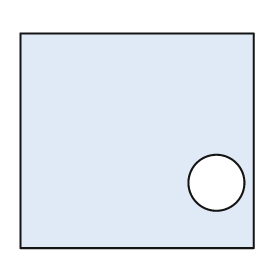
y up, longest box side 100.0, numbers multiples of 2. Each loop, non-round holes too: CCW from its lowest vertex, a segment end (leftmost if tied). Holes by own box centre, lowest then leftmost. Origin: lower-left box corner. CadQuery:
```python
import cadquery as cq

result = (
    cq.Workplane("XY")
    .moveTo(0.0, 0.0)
    .lineTo(100.0, 0.0)
    .lineTo(100.0, 92.0)
    .lineTo(0.0, 92.0)
    .close()
    .moveTo(84.0, 28.0)
    .circle(12.0)
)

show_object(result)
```